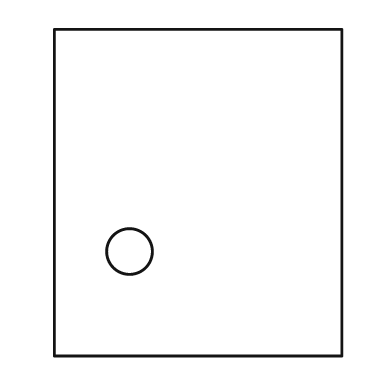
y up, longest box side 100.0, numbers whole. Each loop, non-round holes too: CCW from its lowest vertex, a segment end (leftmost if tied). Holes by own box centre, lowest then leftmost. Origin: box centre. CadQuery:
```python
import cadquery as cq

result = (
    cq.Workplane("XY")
    .moveTo(-44.0, -50.0)
    .lineTo(44.0, -50.0)
    .lineTo(44.0, 50.0)
    .lineTo(-44.0, 50.0)
    .close()
    .moveTo(-21.0, -18.0)
    .circle(7.0)
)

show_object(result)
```